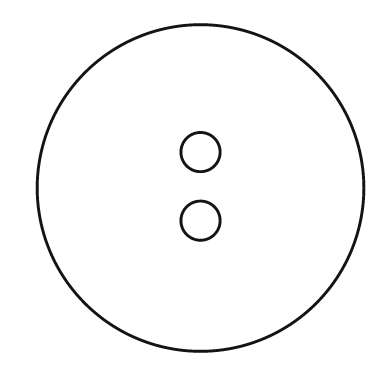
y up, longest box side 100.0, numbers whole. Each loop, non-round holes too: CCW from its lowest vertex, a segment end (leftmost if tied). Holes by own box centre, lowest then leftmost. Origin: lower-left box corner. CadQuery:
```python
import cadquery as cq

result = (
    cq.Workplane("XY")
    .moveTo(50.0, 50.0)
    .circle(50.0)
    .moveTo(50.0, 40.0)
    .circle(6.0)
    .moveTo(50.0, 61.0)
    .circle(6.0)
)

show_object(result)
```